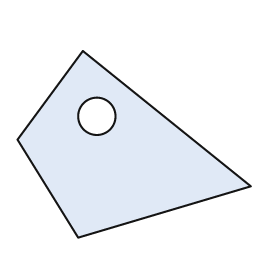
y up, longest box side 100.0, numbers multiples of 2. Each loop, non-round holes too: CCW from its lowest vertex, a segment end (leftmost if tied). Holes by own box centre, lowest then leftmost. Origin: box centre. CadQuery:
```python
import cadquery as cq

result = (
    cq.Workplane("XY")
    .moveTo(-24.0, -40.0)
    .lineTo(50.0, -18.0)
    .lineTo(-22.0, 40.0)
    .lineTo(-50.0, 2.0)
    .close()
    .moveTo(-16.0, 12.0)
    .circle(8.0)
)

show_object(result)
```